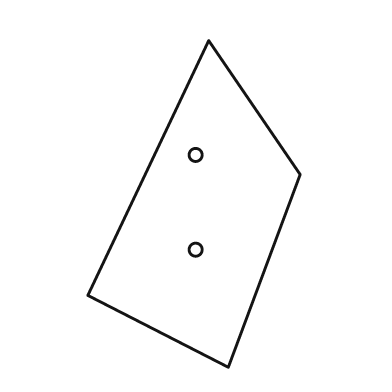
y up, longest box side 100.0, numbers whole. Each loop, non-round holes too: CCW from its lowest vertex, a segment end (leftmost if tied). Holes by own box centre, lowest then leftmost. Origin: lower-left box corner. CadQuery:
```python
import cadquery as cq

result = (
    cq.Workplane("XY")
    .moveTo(43.0, 0.0)
    .lineTo(65.0, 59.0)
    .lineTo(37.0, 100.0)
    .lineTo(0.0, 22.0)
    .close()
    .moveTo(33.0, 36.0)
    .circle(2.0)
    .moveTo(33.0, 65.0)
    .circle(2.0)
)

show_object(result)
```